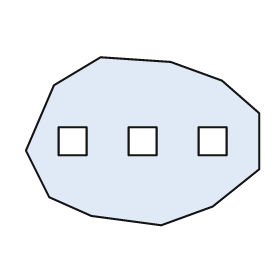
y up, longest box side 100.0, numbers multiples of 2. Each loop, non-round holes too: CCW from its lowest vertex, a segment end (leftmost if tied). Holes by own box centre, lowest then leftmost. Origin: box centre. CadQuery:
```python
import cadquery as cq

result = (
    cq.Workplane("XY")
    .moveTo(8.0, -36.0)
    .lineTo(30.0, -28.0)
    .lineTo(50.0, -12.0)
    .lineTo(50.0, 12.0)
    .lineTo(34.0, 26.0)
    .lineTo(12.0, 34.0)
    .lineTo(-18.0, 36.0)
    .lineTo(-38.0, 24.0)
    .lineTo(-50.0, -4.0)
    .lineTo(-40.0, -24.0)
    .lineTo(-22.0, -32.0)
    .close()
    .moveTo(-36.0, -6.0)
    .lineTo(-24.0, -6.0)
    .lineTo(-24.0, 6.0)
    .lineTo(-36.0, 6.0)
    .close()
    .moveTo(-6.0, -6.0)
    .lineTo(6.0, -6.0)
    .lineTo(6.0, 6.0)
    .lineTo(-6.0, 6.0)
    .close()
    .moveTo(24.0, -6.0)
    .lineTo(36.0, -6.0)
    .lineTo(36.0, 6.0)
    .lineTo(24.0, 6.0)
    .close()
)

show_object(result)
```